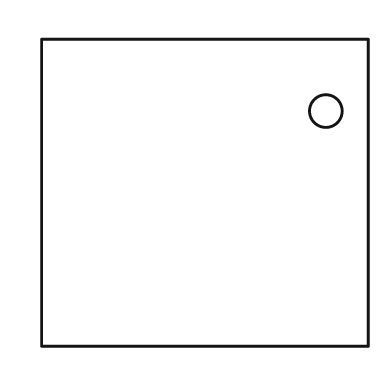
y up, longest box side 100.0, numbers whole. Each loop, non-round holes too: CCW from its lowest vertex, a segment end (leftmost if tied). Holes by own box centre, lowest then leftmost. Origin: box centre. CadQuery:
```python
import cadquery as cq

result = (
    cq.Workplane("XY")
    .moveTo(-50.0, -47.0)
    .lineTo(50.0, -47.0)
    .lineTo(50.0, 47.0)
    .lineTo(-50.0, 47.0)
    .close()
    .moveTo(37.0, 25.0)
    .circle(5.0)
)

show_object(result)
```